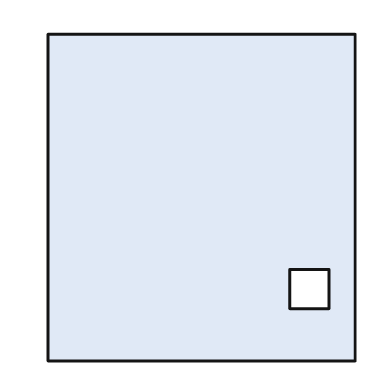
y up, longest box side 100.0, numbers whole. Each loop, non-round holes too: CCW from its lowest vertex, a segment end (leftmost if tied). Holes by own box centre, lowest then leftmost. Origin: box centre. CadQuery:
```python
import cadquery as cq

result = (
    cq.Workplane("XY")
    .moveTo(-47.0, -50.0)
    .lineTo(47.0, -50.0)
    .lineTo(47.0, 50.0)
    .lineTo(-47.0, 50.0)
    .close()
    .moveTo(27.0, -34.0)
    .lineTo(39.0, -34.0)
    .lineTo(39.0, -22.0)
    .lineTo(27.0, -22.0)
    .close()
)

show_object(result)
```